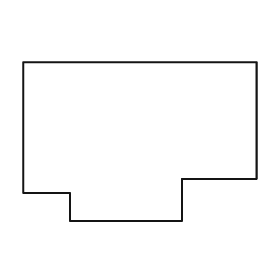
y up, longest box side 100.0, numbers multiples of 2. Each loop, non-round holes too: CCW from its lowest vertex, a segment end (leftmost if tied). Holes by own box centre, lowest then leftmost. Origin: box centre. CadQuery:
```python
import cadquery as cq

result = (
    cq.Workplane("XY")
    .moveTo(-30.0, -34.0)
    .lineTo(18.0, -34.0)
    .lineTo(18.0, -16.0)
    .lineTo(50.0, -16.0)
    .lineTo(50.0, 34.0)
    .lineTo(-50.0, 34.0)
    .lineTo(-50.0, -22.0)
    .lineTo(-30.0, -22.0)
    .close()
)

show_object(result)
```